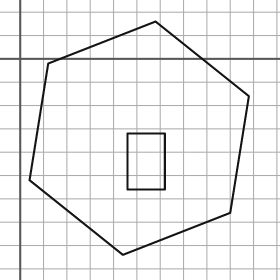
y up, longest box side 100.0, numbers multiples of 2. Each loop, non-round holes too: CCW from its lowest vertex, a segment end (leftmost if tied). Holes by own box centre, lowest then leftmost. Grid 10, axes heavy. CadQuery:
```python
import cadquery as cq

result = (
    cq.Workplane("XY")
    .moveTo(44.0, -84.0)
    .lineTo(90.0, -66.0)
    .lineTo(98.0, -16.0)
    .lineTo(58.0, 16.0)
    .lineTo(12.0, -2.0)
    .lineTo(4.0, -52.0)
    .close()
    .moveTo(46.0, -56.0)
    .lineTo(62.0, -56.0)
    .lineTo(62.0, -32.0)
    .lineTo(46.0, -32.0)
    .close()
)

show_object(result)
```